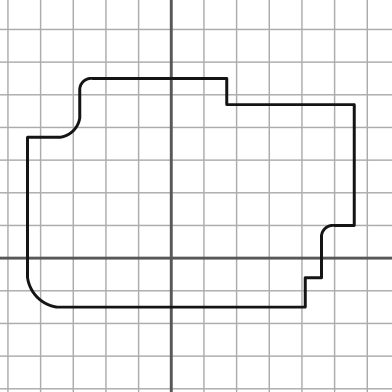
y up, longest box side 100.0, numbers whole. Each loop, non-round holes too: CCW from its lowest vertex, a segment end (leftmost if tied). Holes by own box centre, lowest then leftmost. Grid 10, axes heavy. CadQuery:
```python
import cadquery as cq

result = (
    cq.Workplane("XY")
    .moveTo(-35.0, -15.0)
    .lineTo(41.0, -15.0)
    .lineTo(41.0, -6.0)
    .lineTo(46.0, -6.0)
    .lineTo(46.0, 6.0)
    .threePointArc((47.0, 9.0), (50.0, 10.0))
    .lineTo(56.0, 10.0)
    .lineTo(56.0, 47.0)
    .lineTo(17.0, 47.0)
    .lineTo(17.0, 55.0)
    .lineTo(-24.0, 55.0)
    .threePointArc((-27.0, 54.0), (-28.0, 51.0))
    .lineTo(-28.0, 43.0)
    .threePointArc((-30.0, 39.0), (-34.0, 37.0))
    .lineTo(-44.0, 37.0)
    .lineTo(-44.0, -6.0)
    .threePointArc((-41.0, -12.0), (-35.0, -15.0))
    .close()
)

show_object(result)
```